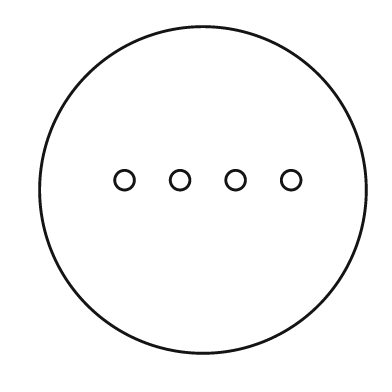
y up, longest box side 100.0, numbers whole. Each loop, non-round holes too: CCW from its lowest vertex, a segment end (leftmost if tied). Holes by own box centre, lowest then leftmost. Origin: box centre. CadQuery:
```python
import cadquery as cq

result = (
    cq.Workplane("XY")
    .moveTo(0.0, 0.0)
    .circle(50.0)
    .moveTo(-24.0, 3.0)
    .circle(3.0)
    .moveTo(-7.0, 3.0)
    .circle(3.0)
    .moveTo(10.0, 3.0)
    .circle(3.0)
    .moveTo(27.0, 3.0)
    .circle(3.0)
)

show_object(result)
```